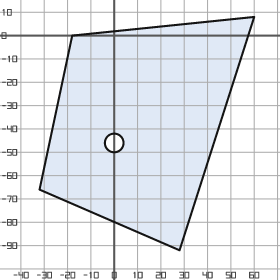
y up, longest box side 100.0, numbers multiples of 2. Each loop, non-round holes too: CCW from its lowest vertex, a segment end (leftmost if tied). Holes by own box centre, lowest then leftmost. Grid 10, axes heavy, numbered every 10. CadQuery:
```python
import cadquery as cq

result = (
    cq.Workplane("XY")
    .moveTo(28.0, -92.0)
    .lineTo(60.0, 8.0)
    .lineTo(-18.0, 0.0)
    .lineTo(-32.0, -66.0)
    .close()
    .moveTo(0.0, -46.0)
    .circle(4.0)
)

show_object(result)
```